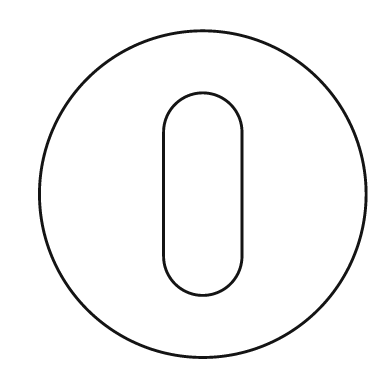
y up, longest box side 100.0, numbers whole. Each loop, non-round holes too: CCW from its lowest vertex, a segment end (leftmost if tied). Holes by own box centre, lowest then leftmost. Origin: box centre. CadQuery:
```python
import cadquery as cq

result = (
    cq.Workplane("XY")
    .moveTo(0.0, 0.0)
    .circle(50.0)
    .moveTo(-12.0, -19.0)
    .threePointArc((0.0, -31.0), (12.0, -19.0))
    .lineTo(12.0, 19.0)
    .threePointArc((0.0, 31.0), (-12.0, 19.0))
    .close()
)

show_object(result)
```